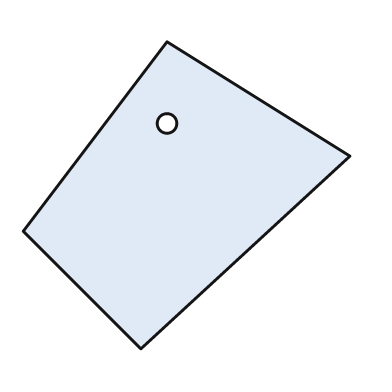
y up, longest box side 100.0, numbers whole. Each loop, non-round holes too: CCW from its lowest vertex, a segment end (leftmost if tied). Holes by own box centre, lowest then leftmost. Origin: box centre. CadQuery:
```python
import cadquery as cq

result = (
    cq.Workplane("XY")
    .moveTo(-14.0, -47.0)
    .lineTo(50.0, 12.0)
    .lineTo(-6.0, 47.0)
    .lineTo(-50.0, -11.0)
    .close()
    .moveTo(-6.0, 22.0)
    .circle(3.0)
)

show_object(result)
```